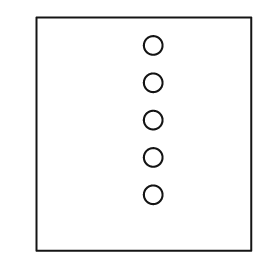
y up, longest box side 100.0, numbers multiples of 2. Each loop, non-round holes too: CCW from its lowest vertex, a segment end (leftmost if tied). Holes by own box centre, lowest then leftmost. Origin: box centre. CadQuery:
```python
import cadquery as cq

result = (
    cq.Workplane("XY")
    .moveTo(-46.0, -50.0)
    .lineTo(46.0, -50.0)
    .lineTo(46.0, 50.0)
    .lineTo(-46.0, 50.0)
    .close()
    .moveTo(4.0, -26.0)
    .circle(4.0)
    .moveTo(4.0, -10.0)
    .circle(4.0)
    .moveTo(4.0, 6.0)
    .circle(4.0)
    .moveTo(4.0, 22.0)
    .circle(4.0)
    .moveTo(4.0, 38.0)
    .circle(4.0)
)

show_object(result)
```